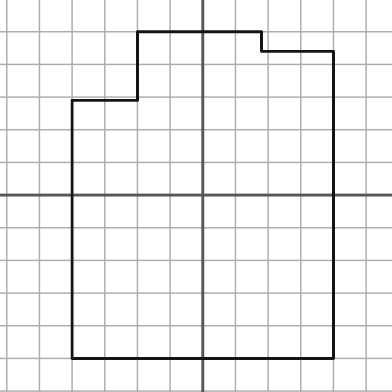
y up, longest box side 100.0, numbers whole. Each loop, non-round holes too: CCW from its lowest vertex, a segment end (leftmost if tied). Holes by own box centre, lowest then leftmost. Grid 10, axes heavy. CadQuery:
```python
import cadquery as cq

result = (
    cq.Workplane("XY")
    .moveTo(-40.0, -50.0)
    .lineTo(40.0, -50.0)
    .lineTo(40.0, 44.0)
    .lineTo(18.0, 44.0)
    .lineTo(18.0, 50.0)
    .lineTo(-20.0, 50.0)
    .lineTo(-20.0, 29.0)
    .lineTo(-40.0, 29.0)
    .close()
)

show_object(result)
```